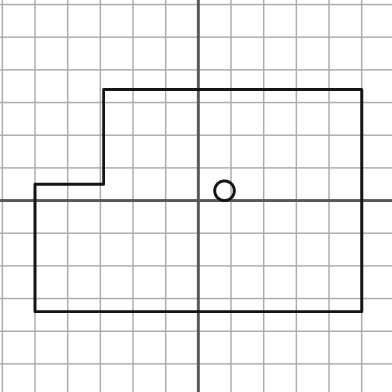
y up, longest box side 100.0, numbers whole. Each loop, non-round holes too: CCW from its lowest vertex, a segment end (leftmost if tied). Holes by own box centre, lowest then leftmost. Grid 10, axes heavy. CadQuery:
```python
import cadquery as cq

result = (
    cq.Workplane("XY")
    .moveTo(-50.0, -34.0)
    .lineTo(50.0, -34.0)
    .lineTo(50.0, 34.0)
    .lineTo(-29.0, 34.0)
    .lineTo(-29.0, 5.0)
    .lineTo(-50.0, 5.0)
    .close()
    .moveTo(8.0, 3.0)
    .circle(3.0)
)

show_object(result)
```